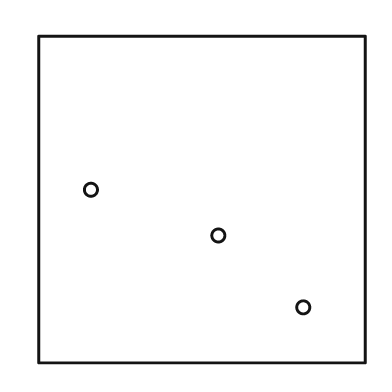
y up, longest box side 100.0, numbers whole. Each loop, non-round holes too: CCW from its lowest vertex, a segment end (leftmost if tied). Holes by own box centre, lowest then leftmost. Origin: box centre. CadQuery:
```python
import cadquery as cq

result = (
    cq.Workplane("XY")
    .moveTo(-50.0, -50.0)
    .lineTo(50.0, -50.0)
    .lineTo(50.0, 50.0)
    .lineTo(-50.0, 50.0)
    .close()
    .moveTo(31.0, -33.0)
    .circle(2.0)
    .moveTo(5.0, -11.0)
    .circle(2.0)
    .moveTo(-34.0, 3.0)
    .circle(2.0)
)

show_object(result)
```